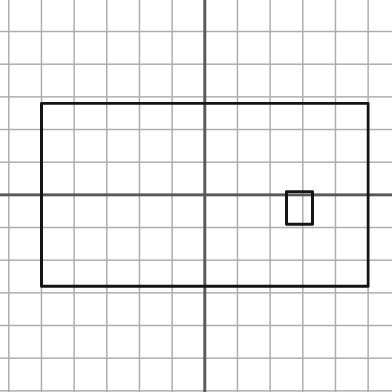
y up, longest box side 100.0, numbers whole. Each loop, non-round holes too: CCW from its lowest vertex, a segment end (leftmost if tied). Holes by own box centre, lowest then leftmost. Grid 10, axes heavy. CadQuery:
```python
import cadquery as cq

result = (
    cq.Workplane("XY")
    .moveTo(-50.0, -28.0)
    .lineTo(50.0, -28.0)
    .lineTo(50.0, 28.0)
    .lineTo(-50.0, 28.0)
    .close()
    .moveTo(25.0, -9.0)
    .lineTo(33.0, -9.0)
    .lineTo(33.0, 1.0)
    .lineTo(25.0, 1.0)
    .close()
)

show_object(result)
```